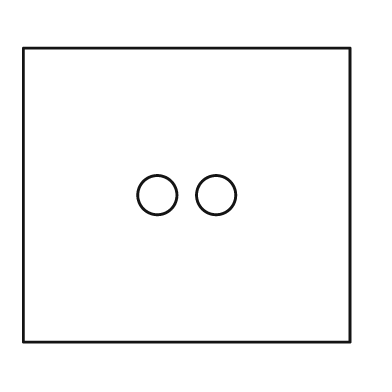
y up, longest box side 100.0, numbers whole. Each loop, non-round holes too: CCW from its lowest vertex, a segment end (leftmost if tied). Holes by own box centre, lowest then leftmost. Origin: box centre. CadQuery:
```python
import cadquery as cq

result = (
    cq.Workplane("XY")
    .moveTo(-50.0, -45.0)
    .lineTo(50.0, -45.0)
    .lineTo(50.0, 45.0)
    .lineTo(-50.0, 45.0)
    .close()
    .moveTo(-9.0, 0.0)
    .circle(6.0)
    .moveTo(9.0, 0.0)
    .circle(6.0)
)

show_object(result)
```